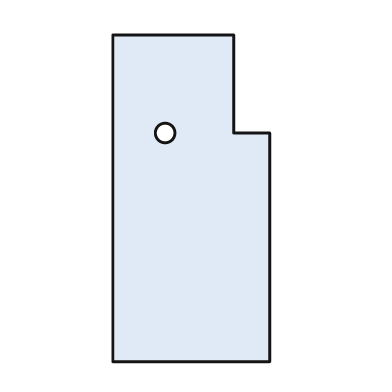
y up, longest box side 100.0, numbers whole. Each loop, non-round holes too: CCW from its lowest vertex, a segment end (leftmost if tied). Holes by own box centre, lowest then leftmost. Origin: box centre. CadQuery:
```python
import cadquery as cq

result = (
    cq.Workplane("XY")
    .moveTo(-24.0, -50.0)
    .lineTo(24.0, -50.0)
    .lineTo(24.0, 20.0)
    .lineTo(13.0, 20.0)
    .lineTo(13.0, 50.0)
    .lineTo(-24.0, 50.0)
    .close()
    .moveTo(-8.0, 20.0)
    .circle(3.0)
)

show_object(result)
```